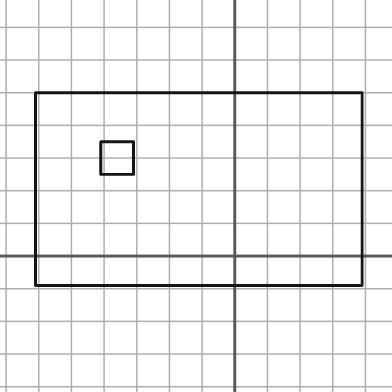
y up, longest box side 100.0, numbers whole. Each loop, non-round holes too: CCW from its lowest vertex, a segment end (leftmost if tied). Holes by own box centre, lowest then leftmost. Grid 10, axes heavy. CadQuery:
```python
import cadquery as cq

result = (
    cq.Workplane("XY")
    .moveTo(-61.0, -9.0)
    .lineTo(39.0, -9.0)
    .lineTo(39.0, 50.0)
    .lineTo(-61.0, 50.0)
    .close()
    .moveTo(-41.0, 25.0)
    .lineTo(-31.0, 25.0)
    .lineTo(-31.0, 35.0)
    .lineTo(-41.0, 35.0)
    .close()
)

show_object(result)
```